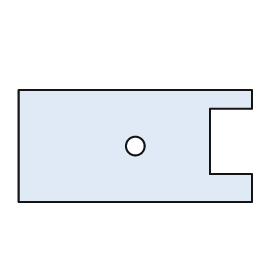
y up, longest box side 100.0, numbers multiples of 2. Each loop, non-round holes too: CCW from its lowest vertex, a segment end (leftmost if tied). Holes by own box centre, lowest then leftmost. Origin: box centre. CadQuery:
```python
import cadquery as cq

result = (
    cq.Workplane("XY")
    .moveTo(-50.0, -24.0)
    .lineTo(50.0, -24.0)
    .lineTo(50.0, -12.0)
    .lineTo(32.0, -12.0)
    .lineTo(32.0, 16.0)
    .lineTo(50.0, 16.0)
    .lineTo(50.0, 24.0)
    .lineTo(-50.0, 24.0)
    .close()
    .moveTo(0.0, 0.0)
    .circle(4.0)
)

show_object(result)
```